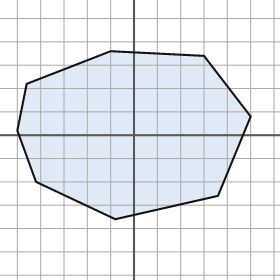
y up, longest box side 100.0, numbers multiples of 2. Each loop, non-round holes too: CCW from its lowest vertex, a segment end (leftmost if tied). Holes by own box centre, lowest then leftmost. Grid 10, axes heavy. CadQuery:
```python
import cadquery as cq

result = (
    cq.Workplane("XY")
    .moveTo(-8.0, -36.0)
    .lineTo(36.0, -26.0)
    .lineTo(50.0, 8.0)
    .lineTo(30.0, 34.0)
    .lineTo(-10.0, 36.0)
    .lineTo(-46.0, 22.0)
    .lineTo(-50.0, 2.0)
    .lineTo(-42.0, -20.0)
    .close()
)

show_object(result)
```